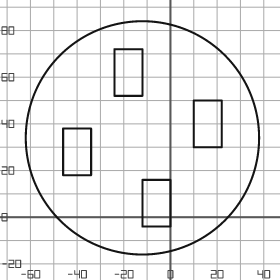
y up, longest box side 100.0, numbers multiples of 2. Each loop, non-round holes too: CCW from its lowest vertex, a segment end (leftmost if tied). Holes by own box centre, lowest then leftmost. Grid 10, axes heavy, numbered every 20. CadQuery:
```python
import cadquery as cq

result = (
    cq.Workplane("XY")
    .moveTo(-12.0, 34.0)
    .circle(50.0)
    .moveTo(-12.0, -4.0)
    .lineTo(0.0, -4.0)
    .lineTo(0.0, 16.0)
    .lineTo(-12.0, 16.0)
    .close()
    .moveTo(-46.0, 18.0)
    .lineTo(-34.0, 18.0)
    .lineTo(-34.0, 38.0)
    .lineTo(-46.0, 38.0)
    .close()
    .moveTo(10.0, 30.0)
    .lineTo(22.0, 30.0)
    .lineTo(22.0, 50.0)
    .lineTo(10.0, 50.0)
    .close()
    .moveTo(-24.0, 52.0)
    .lineTo(-12.0, 52.0)
    .lineTo(-12.0, 72.0)
    .lineTo(-24.0, 72.0)
    .close()
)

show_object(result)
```